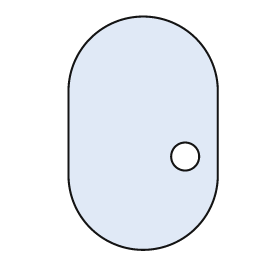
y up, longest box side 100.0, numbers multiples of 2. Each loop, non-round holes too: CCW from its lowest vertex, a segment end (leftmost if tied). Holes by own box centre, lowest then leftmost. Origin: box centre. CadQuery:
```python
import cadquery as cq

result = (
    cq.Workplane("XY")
    .moveTo(-32.0, -18.0)
    .threePointArc((0.0, -50.0), (32.0, -18.0))
    .lineTo(32.0, 18.0)
    .threePointArc((0.0, 50.0), (-32.0, 18.0))
    .close()
    .moveTo(18.0, -10.0)
    .circle(6.0)
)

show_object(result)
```